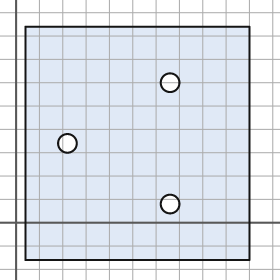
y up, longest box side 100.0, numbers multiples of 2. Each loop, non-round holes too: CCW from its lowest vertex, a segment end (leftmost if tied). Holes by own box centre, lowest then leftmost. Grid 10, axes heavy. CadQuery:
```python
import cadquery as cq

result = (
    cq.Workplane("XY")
    .moveTo(4.0, -16.0)
    .lineTo(100.0, -16.0)
    .lineTo(100.0, 84.0)
    .lineTo(4.0, 84.0)
    .close()
    .moveTo(66.0, 8.0)
    .circle(4.0)
    .moveTo(22.0, 34.0)
    .circle(4.0)
    .moveTo(66.0, 60.0)
    .circle(4.0)
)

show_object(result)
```